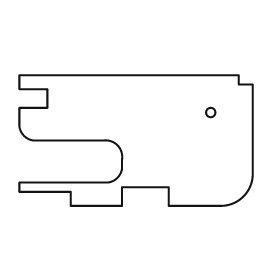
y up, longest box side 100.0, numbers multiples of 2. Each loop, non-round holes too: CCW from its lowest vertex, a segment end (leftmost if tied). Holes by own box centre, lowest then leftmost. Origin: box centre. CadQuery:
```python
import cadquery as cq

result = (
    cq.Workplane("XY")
    .moveTo(-28.0, -28.0)
    .lineTo(-6.0, -28.0)
    .lineTo(-6.0, -20.0)
    .lineTo(14.0, -20.0)
    .lineTo(14.0, -28.0)
    .lineTo(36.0, -28.0)
    .threePointArc((46.0, -24.0), (50.0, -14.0))
    .lineTo(50.0, 24.0)
    .lineTo(44.0, 24.0)
    .lineTo(44.0, 28.0)
    .lineTo(-50.0, 28.0)
    .lineTo(-50.0, 22.0)
    .lineTo(-38.0, 22.0)
    .lineTo(-38.0, 14.0)
    .lineTo(-50.0, 14.0)
    .lineTo(-50.0, 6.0)
    .threePointArc((-48.0, 2.0), (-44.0, 0.0))
    .lineTo(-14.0, 0.0)
    .threePointArc((-8.0, -2.0), (-6.0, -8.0))
    .lineTo(-6.0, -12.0)
    .threePointArc((-8.0, -16.0), (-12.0, -18.0))
    .lineTo(-50.0, -18.0)
    .lineTo(-50.0, -22.0)
    .lineTo(-28.0, -22.0)
    .close()
    .moveTo(32.0, 12.0)
    .circle(2.0)
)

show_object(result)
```